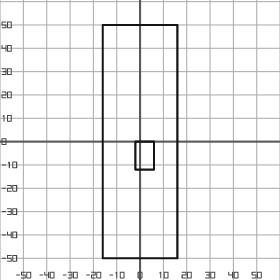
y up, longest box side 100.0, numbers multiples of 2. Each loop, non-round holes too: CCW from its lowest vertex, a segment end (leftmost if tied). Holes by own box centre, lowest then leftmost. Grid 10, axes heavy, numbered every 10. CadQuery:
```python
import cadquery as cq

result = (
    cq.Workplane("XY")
    .moveTo(-16.0, -50.0)
    .lineTo(16.0, -50.0)
    .lineTo(16.0, 50.0)
    .lineTo(-16.0, 50.0)
    .close()
    .moveTo(-2.0, -12.0)
    .lineTo(6.0, -12.0)
    .lineTo(6.0, 0.0)
    .lineTo(-2.0, 0.0)
    .close()
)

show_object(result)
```